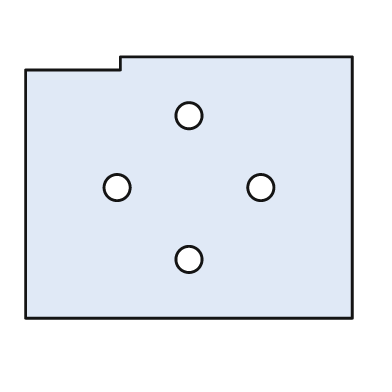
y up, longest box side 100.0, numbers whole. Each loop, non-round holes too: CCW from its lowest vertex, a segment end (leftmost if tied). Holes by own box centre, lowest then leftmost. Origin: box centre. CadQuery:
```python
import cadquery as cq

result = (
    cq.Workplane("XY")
    .moveTo(-50.0, -40.0)
    .lineTo(50.0, -40.0)
    .lineTo(50.0, 40.0)
    .lineTo(-21.0, 40.0)
    .lineTo(-21.0, 36.0)
    .lineTo(-50.0, 36.0)
    .close()
    .moveTo(0.0, -22.0)
    .circle(4.0)
    .moveTo(-22.0, 0.0)
    .circle(4.0)
    .moveTo(22.0, 0.0)
    .circle(4.0)
    .moveTo(0.0, 22.0)
    .circle(4.0)
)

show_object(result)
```